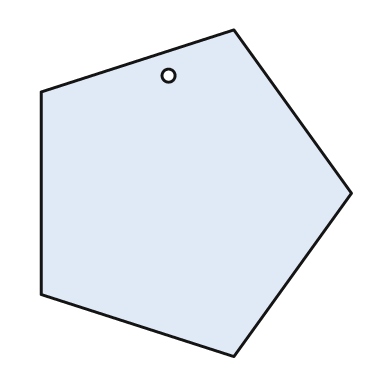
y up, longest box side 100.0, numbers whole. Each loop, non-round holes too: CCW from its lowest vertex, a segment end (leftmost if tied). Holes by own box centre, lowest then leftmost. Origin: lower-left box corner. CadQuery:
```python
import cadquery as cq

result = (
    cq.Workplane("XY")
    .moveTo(59.0, 0.0)
    .lineTo(95.0, 50.0)
    .lineTo(59.0, 100.0)
    .lineTo(0.0, 81.0)
    .lineTo(0.0, 19.0)
    .close()
    .moveTo(39.0, 86.0)
    .circle(2.0)
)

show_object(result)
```